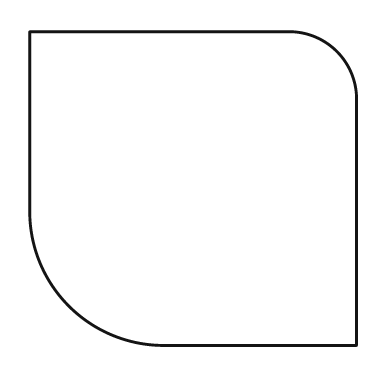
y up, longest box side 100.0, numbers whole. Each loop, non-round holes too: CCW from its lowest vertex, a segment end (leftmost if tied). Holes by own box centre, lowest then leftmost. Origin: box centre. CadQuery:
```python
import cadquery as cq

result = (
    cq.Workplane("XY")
    .moveTo(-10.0, -48.0)
    .lineTo(50.0, -48.0)
    .lineTo(50.0, 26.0)
    .threePointArc((44.0, 42.0), (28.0, 48.0))
    .lineTo(-50.0, 48.0)
    .lineTo(-50.0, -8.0)
    .threePointArc((-38.0, -36.0), (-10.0, -48.0))
    .close()
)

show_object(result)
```